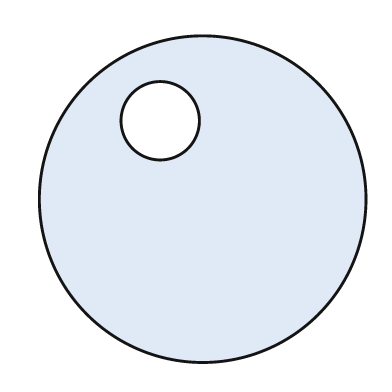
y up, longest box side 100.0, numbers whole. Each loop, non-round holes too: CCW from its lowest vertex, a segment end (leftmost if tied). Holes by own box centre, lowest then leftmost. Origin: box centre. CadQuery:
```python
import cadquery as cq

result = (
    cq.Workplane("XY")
    .moveTo(0.0, 0.0)
    .circle(50.0)
    .moveTo(-13.0, 24.0)
    .circle(12.0)
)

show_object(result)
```